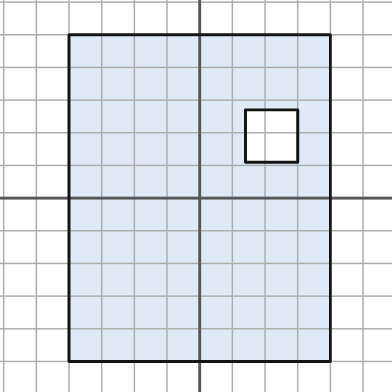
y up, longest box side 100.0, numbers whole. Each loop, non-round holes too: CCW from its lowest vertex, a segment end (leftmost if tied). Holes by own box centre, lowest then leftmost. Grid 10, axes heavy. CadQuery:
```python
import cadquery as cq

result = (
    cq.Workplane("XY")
    .moveTo(-40.0, -50.0)
    .lineTo(40.0, -50.0)
    .lineTo(40.0, 50.0)
    .lineTo(-40.0, 50.0)
    .close()
    .moveTo(14.0, 11.0)
    .lineTo(30.0, 11.0)
    .lineTo(30.0, 27.0)
    .lineTo(14.0, 27.0)
    .close()
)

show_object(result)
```